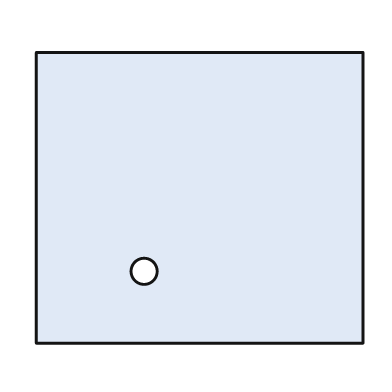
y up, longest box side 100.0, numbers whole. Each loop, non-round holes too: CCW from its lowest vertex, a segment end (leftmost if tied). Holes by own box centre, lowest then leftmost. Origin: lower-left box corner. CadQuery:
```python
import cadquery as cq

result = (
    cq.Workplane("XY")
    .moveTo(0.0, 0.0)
    .lineTo(100.0, 0.0)
    .lineTo(100.0, 89.0)
    .lineTo(0.0, 89.0)
    .close()
    .moveTo(33.0, 22.0)
    .circle(4.0)
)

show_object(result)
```